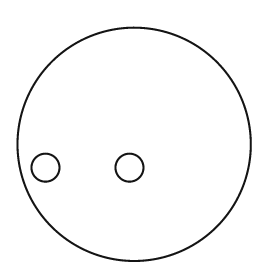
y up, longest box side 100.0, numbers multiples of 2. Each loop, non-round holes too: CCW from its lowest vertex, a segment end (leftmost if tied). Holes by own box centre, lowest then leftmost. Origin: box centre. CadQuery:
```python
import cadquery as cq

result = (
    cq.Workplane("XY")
    .moveTo(0.0, 0.0)
    .circle(50.0)
    .moveTo(-38.0, -10.0)
    .circle(6.0)
    .moveTo(-2.0, -10.0)
    .circle(6.0)
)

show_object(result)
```